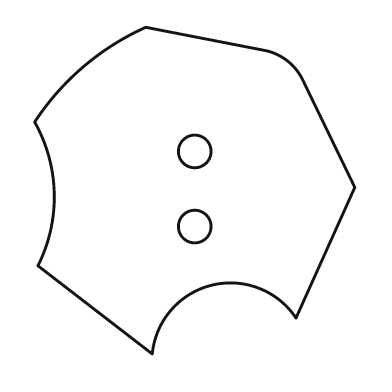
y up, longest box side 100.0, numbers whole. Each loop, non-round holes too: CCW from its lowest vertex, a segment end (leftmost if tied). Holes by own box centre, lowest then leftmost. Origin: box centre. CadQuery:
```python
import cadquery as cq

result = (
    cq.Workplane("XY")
    .moveTo(-13.0, -50.0)
    .threePointArc((5.0, -29.0), (31.0, -39.0))
    .lineTo(49.0, 1.0)
    .lineTo(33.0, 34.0)
    .threePointArc((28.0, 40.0), (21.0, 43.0))
    .lineTo(-15.0, 50.0)
    .threePointArc((-34.0, 38.0), (-49.0, 21.0))
    .threePointArc((-43.0, -1.0), (-48.0, -23.0))
    .close()
    .moveTo(0.0, -11.0)
    .circle(5.0)
    .moveTo(0.0, 12.0)
    .circle(5.0)
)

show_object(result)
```